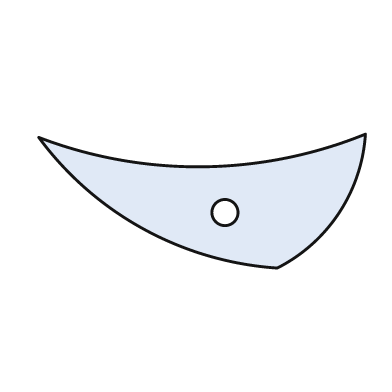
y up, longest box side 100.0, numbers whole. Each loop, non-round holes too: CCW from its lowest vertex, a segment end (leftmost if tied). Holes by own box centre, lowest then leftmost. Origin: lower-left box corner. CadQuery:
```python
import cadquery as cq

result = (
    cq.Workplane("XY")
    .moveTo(73.0, 0.0)
    .threePointArc((92.0, 17.0), (100.0, 41.0))
    .threePointArc((50.0, 31.0), (0.0, 40.0))
    .threePointArc((32.0, 12.0), (73.0, 0.0))
    .close()
    .moveTo(57.0, 17.0)
    .circle(4.0)
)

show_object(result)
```